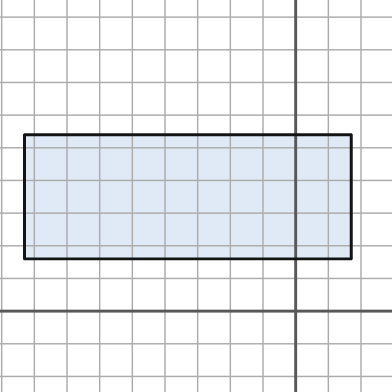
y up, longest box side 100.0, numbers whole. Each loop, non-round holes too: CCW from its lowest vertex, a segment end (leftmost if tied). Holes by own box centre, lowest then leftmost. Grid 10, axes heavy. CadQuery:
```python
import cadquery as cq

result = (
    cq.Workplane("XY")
    .moveTo(-83.0, 16.0)
    .lineTo(17.0, 16.0)
    .lineTo(17.0, 54.0)
    .lineTo(-83.0, 54.0)
    .close()
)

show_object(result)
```